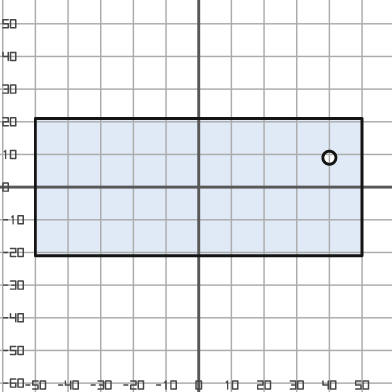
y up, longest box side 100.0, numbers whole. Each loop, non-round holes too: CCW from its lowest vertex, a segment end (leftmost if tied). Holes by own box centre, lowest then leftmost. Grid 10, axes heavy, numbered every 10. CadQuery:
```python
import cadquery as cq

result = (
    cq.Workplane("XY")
    .moveTo(-50.0, -21.0)
    .lineTo(50.0, -21.0)
    .lineTo(50.0, 21.0)
    .lineTo(-50.0, 21.0)
    .close()
    .moveTo(40.0, 9.0)
    .circle(2.0)
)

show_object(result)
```